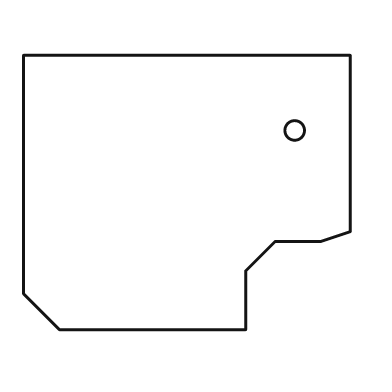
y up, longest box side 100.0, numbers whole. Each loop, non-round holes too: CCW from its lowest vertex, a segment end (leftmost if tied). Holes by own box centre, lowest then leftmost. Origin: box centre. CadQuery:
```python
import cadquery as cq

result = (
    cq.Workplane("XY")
    .moveTo(-39.0, -42.0)
    .lineTo(18.0, -42.0)
    .lineTo(18.0, -24.0)
    .lineTo(27.0, -15.0)
    .lineTo(41.0, -15.0)
    .lineTo(50.0, -12.0)
    .lineTo(50.0, 42.0)
    .lineTo(-50.0, 42.0)
    .lineTo(-50.0, -31.0)
    .close()
    .moveTo(33.0, 19.0)
    .circle(3.0)
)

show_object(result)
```